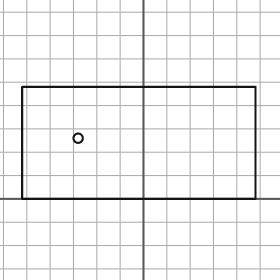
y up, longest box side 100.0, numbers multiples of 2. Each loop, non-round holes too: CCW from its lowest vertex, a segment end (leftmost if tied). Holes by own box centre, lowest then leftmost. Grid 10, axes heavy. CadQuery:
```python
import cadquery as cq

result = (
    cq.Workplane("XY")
    .moveTo(-52.0, 0.0)
    .lineTo(48.0, 0.0)
    .lineTo(48.0, 48.0)
    .lineTo(-52.0, 48.0)
    .close()
    .moveTo(-28.0, 26.0)
    .circle(2.0)
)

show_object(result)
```